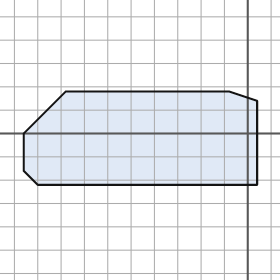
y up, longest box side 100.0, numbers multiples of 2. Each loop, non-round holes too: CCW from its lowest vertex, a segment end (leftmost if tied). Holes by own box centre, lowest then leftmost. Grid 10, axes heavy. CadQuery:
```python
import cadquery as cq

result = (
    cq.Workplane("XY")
    .moveTo(-90.0, -22.0)
    .lineTo(4.0, -22.0)
    .lineTo(4.0, 14.0)
    .lineTo(-8.0, 18.0)
    .lineTo(-78.0, 18.0)
    .lineTo(-96.0, 0.0)
    .lineTo(-96.0, -16.0)
    .close()
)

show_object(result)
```